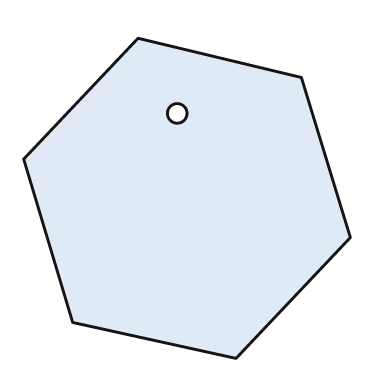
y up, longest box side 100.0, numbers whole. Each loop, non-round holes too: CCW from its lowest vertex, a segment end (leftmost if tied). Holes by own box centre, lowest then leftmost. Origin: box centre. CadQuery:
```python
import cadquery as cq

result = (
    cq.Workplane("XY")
    .moveTo(15.0, -49.0)
    .lineTo(50.0, -12.0)
    .lineTo(35.0, 37.0)
    .lineTo(-15.0, 49.0)
    .lineTo(-50.0, 12.0)
    .lineTo(-35.0, -38.0)
    .close()
    .moveTo(-3.0, 26.0)
    .circle(3.0)
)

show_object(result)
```